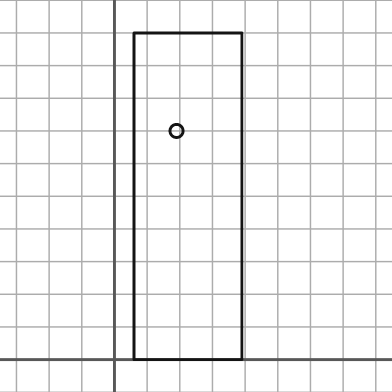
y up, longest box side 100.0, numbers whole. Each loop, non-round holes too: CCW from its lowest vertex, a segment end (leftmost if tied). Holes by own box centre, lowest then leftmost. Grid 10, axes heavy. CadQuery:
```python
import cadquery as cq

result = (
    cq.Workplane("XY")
    .moveTo(6.0, 0.0)
    .lineTo(39.0, 0.0)
    .lineTo(39.0, 100.0)
    .lineTo(6.0, 100.0)
    .close()
    .moveTo(19.0, 70.0)
    .circle(2.0)
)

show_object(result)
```